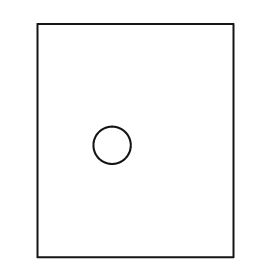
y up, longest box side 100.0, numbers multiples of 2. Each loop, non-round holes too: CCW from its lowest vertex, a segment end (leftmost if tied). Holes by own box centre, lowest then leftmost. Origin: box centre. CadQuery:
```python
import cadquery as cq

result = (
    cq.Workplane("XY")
    .moveTo(-42.0, -50.0)
    .lineTo(42.0, -50.0)
    .lineTo(42.0, 50.0)
    .lineTo(-42.0, 50.0)
    .close()
    .moveTo(-10.0, -2.0)
    .circle(8.0)
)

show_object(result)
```